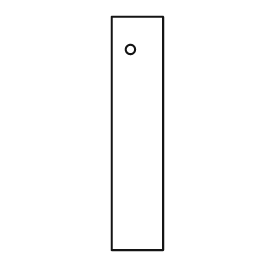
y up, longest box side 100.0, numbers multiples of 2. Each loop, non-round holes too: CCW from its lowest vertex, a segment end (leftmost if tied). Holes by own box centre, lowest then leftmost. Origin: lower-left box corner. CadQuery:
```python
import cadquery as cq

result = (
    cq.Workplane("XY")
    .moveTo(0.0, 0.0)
    .lineTo(22.0, 0.0)
    .lineTo(22.0, 100.0)
    .lineTo(0.0, 100.0)
    .close()
    .moveTo(8.0, 86.0)
    .circle(2.0)
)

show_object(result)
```